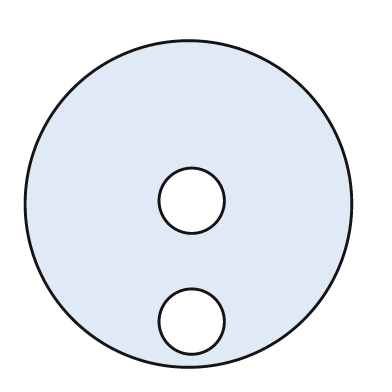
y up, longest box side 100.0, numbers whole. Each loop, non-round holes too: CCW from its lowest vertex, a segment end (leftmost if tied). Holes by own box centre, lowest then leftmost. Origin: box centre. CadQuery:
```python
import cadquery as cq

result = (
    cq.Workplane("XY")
    .moveTo(0.0, 0.0)
    .circle(50.0)
    .moveTo(1.0, -36.0)
    .circle(10.0)
    .moveTo(1.0, 1.0)
    .circle(10.0)
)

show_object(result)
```